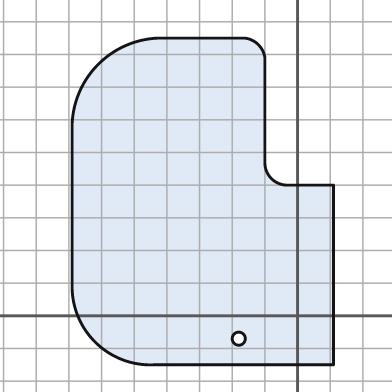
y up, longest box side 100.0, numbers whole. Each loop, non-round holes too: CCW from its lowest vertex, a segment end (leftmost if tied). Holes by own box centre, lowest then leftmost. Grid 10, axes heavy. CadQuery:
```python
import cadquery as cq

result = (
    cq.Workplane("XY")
    .moveTo(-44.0, -15.0)
    .lineTo(11.0, -15.0)
    .lineTo(11.0, 40.0)
    .lineTo(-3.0, 40.0)
    .threePointArc((-8.0, 42.0), (-10.0, 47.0))
    .lineTo(-10.0, 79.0)
    .threePointArc((-12.0, 83.0), (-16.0, 85.0))
    .lineTo(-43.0, 85.0)
    .threePointArc((-61.0, 77.0), (-69.0, 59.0))
    .lineTo(-69.0, 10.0)
    .threePointArc((-62.0, -8.0), (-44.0, -15.0))
    .close()
    .moveTo(-18.0, -7.0)
    .circle(2.0)
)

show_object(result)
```